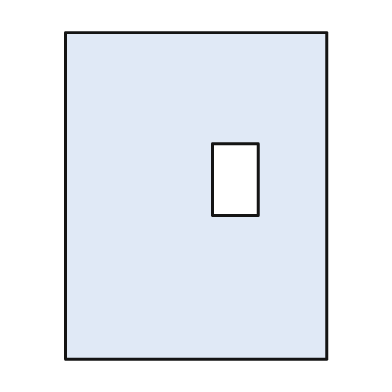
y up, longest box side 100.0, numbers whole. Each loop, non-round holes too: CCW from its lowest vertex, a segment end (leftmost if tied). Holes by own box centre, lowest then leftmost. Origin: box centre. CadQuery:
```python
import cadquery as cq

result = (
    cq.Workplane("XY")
    .moveTo(-40.0, -50.0)
    .lineTo(40.0, -50.0)
    .lineTo(40.0, 50.0)
    .lineTo(-40.0, 50.0)
    .close()
    .moveTo(5.0, -6.0)
    .lineTo(19.0, -6.0)
    .lineTo(19.0, 16.0)
    .lineTo(5.0, 16.0)
    .close()
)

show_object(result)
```